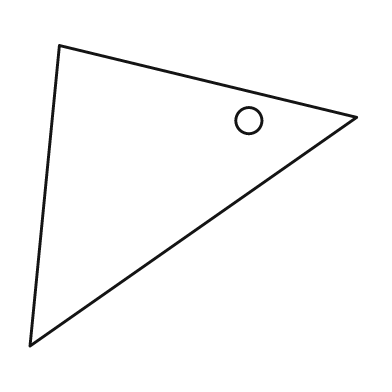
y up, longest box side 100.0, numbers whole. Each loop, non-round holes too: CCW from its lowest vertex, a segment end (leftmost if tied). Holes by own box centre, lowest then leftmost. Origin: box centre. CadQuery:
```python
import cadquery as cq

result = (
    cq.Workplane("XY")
    .moveTo(-50.0, -46.0)
    .lineTo(50.0, 24.0)
    .lineTo(-41.0, 46.0)
    .close()
    .moveTo(17.0, 23.0)
    .circle(4.0)
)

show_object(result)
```